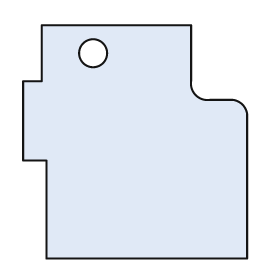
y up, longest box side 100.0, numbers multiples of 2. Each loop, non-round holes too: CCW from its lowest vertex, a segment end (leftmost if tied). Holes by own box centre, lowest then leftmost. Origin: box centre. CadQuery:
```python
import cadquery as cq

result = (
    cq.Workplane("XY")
    .moveTo(-38.0, -50.0)
    .lineTo(48.0, -50.0)
    .lineTo(48.0, 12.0)
    .threePointArc((46.0, 16.0), (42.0, 18.0))
    .lineTo(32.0, 18.0)
    .threePointArc((26.0, 20.0), (24.0, 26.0))
    .lineTo(24.0, 50.0)
    .lineTo(-40.0, 50.0)
    .lineTo(-40.0, 26.0)
    .lineTo(-48.0, 26.0)
    .lineTo(-48.0, -8.0)
    .lineTo(-38.0, -8.0)
    .close()
    .moveTo(-18.0, 38.0)
    .circle(6.0)
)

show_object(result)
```